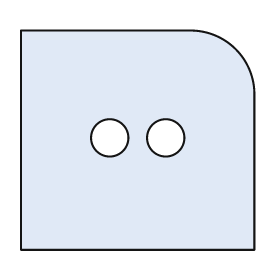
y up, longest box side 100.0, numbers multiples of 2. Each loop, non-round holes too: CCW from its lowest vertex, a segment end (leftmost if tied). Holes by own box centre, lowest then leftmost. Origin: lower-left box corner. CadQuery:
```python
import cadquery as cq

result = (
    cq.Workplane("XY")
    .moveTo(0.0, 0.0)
    .lineTo(100.0, 0.0)
    .lineTo(100.0, 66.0)
    .threePointArc((92.0, 86.0), (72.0, 94.0))
    .lineTo(0.0, 94.0)
    .close()
    .moveTo(38.0, 48.0)
    .circle(8.0)
    .moveTo(62.0, 48.0)
    .circle(8.0)
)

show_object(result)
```